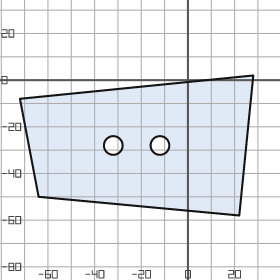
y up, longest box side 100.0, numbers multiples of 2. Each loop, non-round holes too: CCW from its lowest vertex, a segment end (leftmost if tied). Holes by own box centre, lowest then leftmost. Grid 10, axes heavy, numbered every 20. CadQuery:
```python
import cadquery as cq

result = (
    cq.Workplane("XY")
    .moveTo(22.0, -58.0)
    .lineTo(28.0, 2.0)
    .lineTo(-72.0, -8.0)
    .lineTo(-64.0, -50.0)
    .close()
    .moveTo(-32.0, -28.0)
    .circle(4.0)
    .moveTo(-12.0, -28.0)
    .circle(4.0)
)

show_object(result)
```